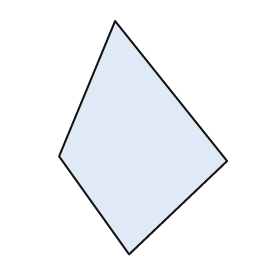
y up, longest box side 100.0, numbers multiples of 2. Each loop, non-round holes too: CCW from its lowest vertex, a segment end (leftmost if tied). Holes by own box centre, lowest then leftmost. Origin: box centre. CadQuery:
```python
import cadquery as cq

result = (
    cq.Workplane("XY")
    .moveTo(-6.0, -50.0)
    .lineTo(36.0, -10.0)
    .lineTo(-12.0, 50.0)
    .lineTo(-36.0, -8.0)
    .close()
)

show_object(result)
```